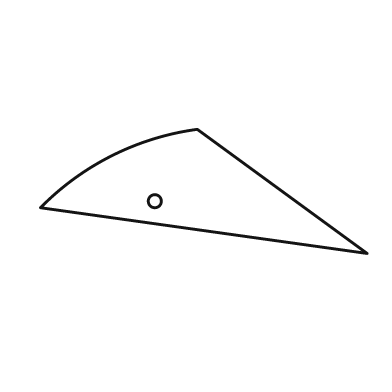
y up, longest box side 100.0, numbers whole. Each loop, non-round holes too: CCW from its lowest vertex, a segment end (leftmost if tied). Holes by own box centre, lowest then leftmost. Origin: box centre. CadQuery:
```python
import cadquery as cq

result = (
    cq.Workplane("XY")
    .moveTo(50.0, -19.0)
    .lineTo(-2.0, 19.0)
    .threePointArc((-28.0, 11.0), (-50.0, -5.0))
    .close()
    .moveTo(-15.0, -3.0)
    .circle(2.0)
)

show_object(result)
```